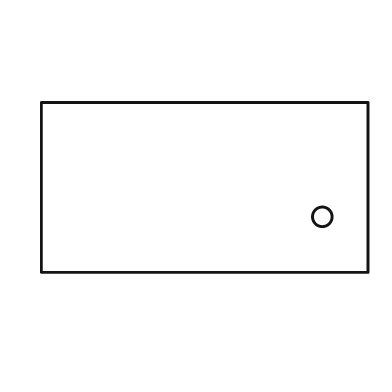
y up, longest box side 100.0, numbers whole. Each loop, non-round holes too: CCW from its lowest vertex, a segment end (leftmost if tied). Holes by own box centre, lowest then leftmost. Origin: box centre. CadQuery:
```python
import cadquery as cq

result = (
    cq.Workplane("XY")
    .moveTo(-50.0, -26.0)
    .lineTo(50.0, -26.0)
    .lineTo(50.0, 26.0)
    .lineTo(-50.0, 26.0)
    .close()
    .moveTo(36.0, -9.0)
    .circle(3.0)
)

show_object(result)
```